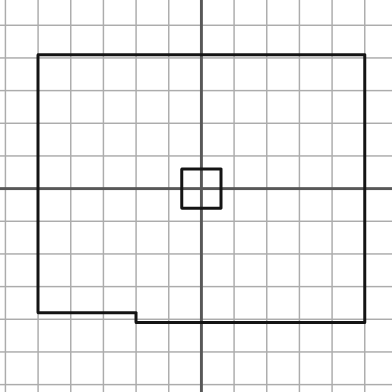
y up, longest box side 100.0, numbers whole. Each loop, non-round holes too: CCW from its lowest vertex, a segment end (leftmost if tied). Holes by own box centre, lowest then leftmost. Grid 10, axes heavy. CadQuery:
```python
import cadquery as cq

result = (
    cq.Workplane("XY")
    .moveTo(-20.0, -41.0)
    .lineTo(50.0, -41.0)
    .lineTo(50.0, 41.0)
    .lineTo(-50.0, 41.0)
    .lineTo(-50.0, -38.0)
    .lineTo(-20.0, -38.0)
    .close()
    .moveTo(-6.0, -6.0)
    .lineTo(6.0, -6.0)
    .lineTo(6.0, 6.0)
    .lineTo(-6.0, 6.0)
    .close()
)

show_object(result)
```